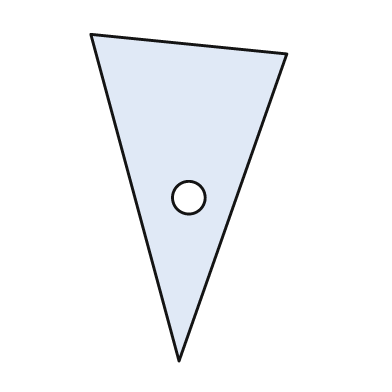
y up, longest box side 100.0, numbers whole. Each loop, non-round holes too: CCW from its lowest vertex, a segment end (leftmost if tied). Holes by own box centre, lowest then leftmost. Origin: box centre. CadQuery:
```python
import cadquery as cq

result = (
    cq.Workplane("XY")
    .moveTo(-3.0, -50.0)
    .lineTo(30.0, 44.0)
    .lineTo(-30.0, 50.0)
    .close()
    .moveTo(0.0, 0.0)
    .circle(5.0)
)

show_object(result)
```